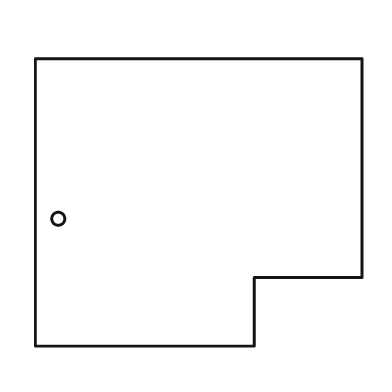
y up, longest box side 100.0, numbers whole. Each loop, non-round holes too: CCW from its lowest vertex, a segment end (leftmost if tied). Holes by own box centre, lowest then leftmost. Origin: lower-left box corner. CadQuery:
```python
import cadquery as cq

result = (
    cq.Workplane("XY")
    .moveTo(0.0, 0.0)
    .lineTo(67.0, 0.0)
    .lineTo(67.0, 21.0)
    .lineTo(100.0, 21.0)
    .lineTo(100.0, 88.0)
    .lineTo(0.0, 88.0)
    .close()
    .moveTo(7.0, 39.0)
    .circle(2.0)
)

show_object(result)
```